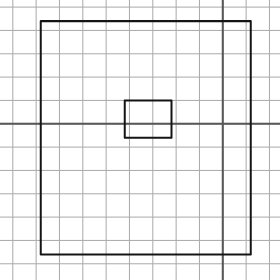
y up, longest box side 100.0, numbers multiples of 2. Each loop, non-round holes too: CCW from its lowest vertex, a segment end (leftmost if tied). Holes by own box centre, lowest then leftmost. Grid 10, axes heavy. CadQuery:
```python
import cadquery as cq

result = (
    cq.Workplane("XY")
    .moveTo(-78.0, -56.0)
    .lineTo(12.0, -56.0)
    .lineTo(12.0, 44.0)
    .lineTo(-78.0, 44.0)
    .close()
    .moveTo(-42.0, -6.0)
    .lineTo(-22.0, -6.0)
    .lineTo(-22.0, 10.0)
    .lineTo(-42.0, 10.0)
    .close()
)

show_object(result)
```